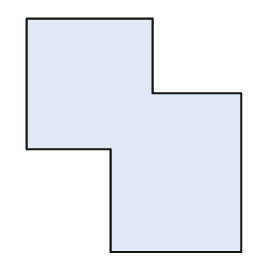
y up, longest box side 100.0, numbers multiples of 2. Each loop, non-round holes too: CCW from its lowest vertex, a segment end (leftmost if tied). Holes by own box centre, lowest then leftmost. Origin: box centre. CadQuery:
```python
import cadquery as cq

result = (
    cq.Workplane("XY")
    .moveTo(-10.0, -50.0)
    .lineTo(46.0, -50.0)
    .lineTo(46.0, 18.0)
    .lineTo(8.0, 18.0)
    .lineTo(8.0, 50.0)
    .lineTo(-46.0, 50.0)
    .lineTo(-46.0, -6.0)
    .lineTo(-10.0, -6.0)
    .close()
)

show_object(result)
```